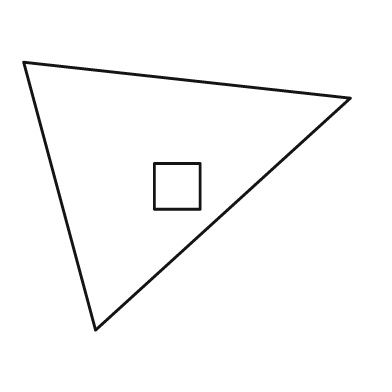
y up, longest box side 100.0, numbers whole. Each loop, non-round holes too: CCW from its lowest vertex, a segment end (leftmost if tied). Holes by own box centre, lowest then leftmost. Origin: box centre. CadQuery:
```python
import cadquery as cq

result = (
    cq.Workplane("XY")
    .moveTo(-28.0, -41.0)
    .lineTo(50.0, 30.0)
    .lineTo(-50.0, 41.0)
    .close()
    .moveTo(-10.0, -4.0)
    .lineTo(4.0, -4.0)
    .lineTo(4.0, 10.0)
    .lineTo(-10.0, 10.0)
    .close()
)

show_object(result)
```